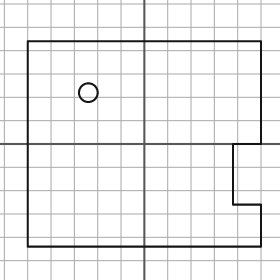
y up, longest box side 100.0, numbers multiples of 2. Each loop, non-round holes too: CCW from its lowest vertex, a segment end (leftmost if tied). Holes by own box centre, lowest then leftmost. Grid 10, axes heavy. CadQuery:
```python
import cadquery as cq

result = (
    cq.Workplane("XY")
    .moveTo(-50.0, -44.0)
    .lineTo(50.0, -44.0)
    .lineTo(50.0, -26.0)
    .lineTo(38.0, -26.0)
    .lineTo(38.0, 0.0)
    .lineTo(50.0, 0.0)
    .lineTo(50.0, 44.0)
    .lineTo(-50.0, 44.0)
    .close()
    .moveTo(-24.0, 22.0)
    .circle(4.0)
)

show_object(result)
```